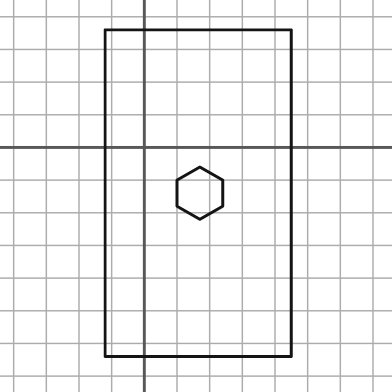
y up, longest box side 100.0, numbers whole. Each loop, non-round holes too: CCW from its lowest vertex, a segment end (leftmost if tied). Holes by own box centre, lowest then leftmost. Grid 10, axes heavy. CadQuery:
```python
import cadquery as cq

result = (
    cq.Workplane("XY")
    .moveTo(-12.0, -64.0)
    .lineTo(45.0, -64.0)
    .lineTo(45.0, 36.0)
    .lineTo(-12.0, 36.0)
    .close()
    .moveTo(17.0, -22.0)
    .lineTo(24.0, -18.0)
    .lineTo(24.0, -10.0)
    .lineTo(17.0, -6.0)
    .lineTo(10.0, -10.0)
    .lineTo(10.0, -18.0)
    .close()
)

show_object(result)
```